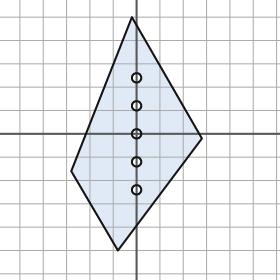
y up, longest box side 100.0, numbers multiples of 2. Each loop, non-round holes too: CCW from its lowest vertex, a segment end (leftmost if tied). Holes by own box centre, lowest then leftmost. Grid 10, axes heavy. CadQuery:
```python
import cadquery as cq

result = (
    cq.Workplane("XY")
    .moveTo(-8.0, -50.0)
    .lineTo(28.0, -2.0)
    .lineTo(-2.0, 50.0)
    .lineTo(-28.0, -16.0)
    .close()
    .moveTo(0.0, -24.0)
    .circle(2.0)
    .moveTo(0.0, -12.0)
    .circle(2.0)
    .moveTo(0.0, 0.0)
    .circle(2.0)
    .moveTo(0.0, 12.0)
    .circle(2.0)
    .moveTo(0.0, 24.0)
    .circle(2.0)
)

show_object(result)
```